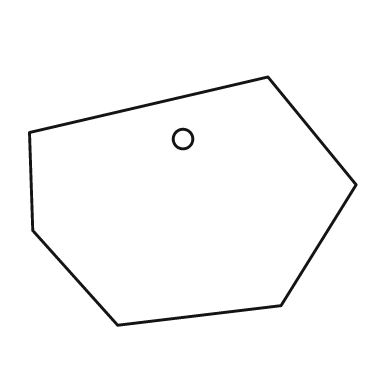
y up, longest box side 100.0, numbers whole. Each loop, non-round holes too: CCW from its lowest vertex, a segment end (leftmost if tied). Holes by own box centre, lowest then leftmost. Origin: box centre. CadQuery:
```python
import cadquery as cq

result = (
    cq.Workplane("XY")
    .moveTo(-23.0, -38.0)
    .lineTo(27.0, -32.0)
    .lineTo(50.0, 5.0)
    .lineTo(23.0, 38.0)
    .lineTo(-50.0, 21.0)
    .lineTo(-49.0, -9.0)
    .close()
    .moveTo(-3.0, 19.0)
    .circle(3.0)
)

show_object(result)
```